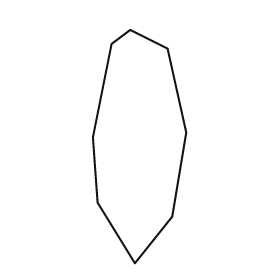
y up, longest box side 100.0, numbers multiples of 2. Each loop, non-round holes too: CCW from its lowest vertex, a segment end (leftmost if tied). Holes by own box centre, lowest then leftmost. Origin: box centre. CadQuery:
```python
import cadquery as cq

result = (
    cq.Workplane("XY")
    .moveTo(-2.0, -50.0)
    .lineTo(14.0, -30.0)
    .lineTo(20.0, 6.0)
    .lineTo(12.0, 42.0)
    .lineTo(-4.0, 50.0)
    .lineTo(-12.0, 44.0)
    .lineTo(-20.0, 4.0)
    .lineTo(-18.0, -24.0)
    .close()
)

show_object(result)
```